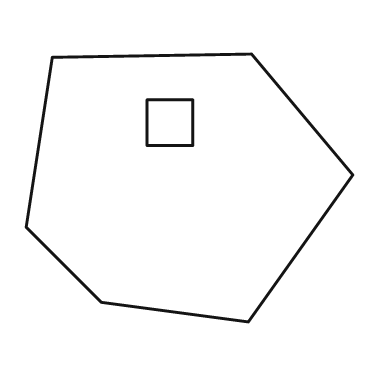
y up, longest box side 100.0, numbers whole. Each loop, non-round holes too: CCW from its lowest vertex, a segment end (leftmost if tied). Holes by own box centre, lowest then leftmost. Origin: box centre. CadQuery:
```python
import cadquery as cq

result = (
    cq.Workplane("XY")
    .moveTo(18.0, -41.0)
    .lineTo(50.0, 4.0)
    .lineTo(19.0, 41.0)
    .lineTo(-42.0, 40.0)
    .lineTo(-50.0, -12.0)
    .lineTo(-27.0, -35.0)
    .close()
    .moveTo(-13.0, 13.0)
    .lineTo(1.0, 13.0)
    .lineTo(1.0, 27.0)
    .lineTo(-13.0, 27.0)
    .close()
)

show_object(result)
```